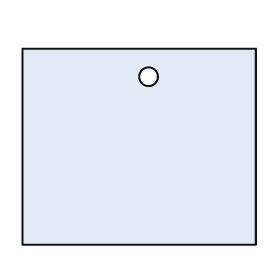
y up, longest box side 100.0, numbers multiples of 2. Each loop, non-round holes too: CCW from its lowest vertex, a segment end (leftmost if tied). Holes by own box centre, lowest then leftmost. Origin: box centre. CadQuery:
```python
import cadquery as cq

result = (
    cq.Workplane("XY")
    .moveTo(-50.0, -42.0)
    .lineTo(50.0, -42.0)
    .lineTo(50.0, 42.0)
    .lineTo(-50.0, 42.0)
    .close()
    .moveTo(4.0, 30.0)
    .circle(4.0)
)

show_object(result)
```